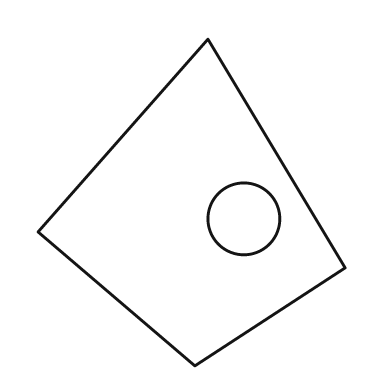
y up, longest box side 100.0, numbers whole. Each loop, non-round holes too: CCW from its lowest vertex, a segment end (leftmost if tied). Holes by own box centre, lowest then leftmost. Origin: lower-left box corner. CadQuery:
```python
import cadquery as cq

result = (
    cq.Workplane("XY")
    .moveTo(48.0, 0.0)
    .lineTo(94.0, 30.0)
    .lineTo(52.0, 100.0)
    .lineTo(0.0, 41.0)
    .close()
    .moveTo(63.0, 45.0)
    .circle(11.0)
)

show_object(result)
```